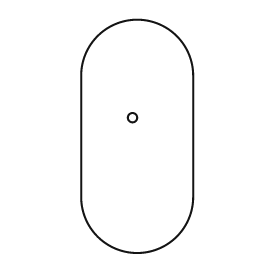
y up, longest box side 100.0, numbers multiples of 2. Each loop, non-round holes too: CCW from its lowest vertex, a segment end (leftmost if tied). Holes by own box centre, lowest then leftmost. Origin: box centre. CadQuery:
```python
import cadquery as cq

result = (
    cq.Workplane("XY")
    .moveTo(-24.0, -26.0)
    .threePointArc((0.0, -50.0), (24.0, -26.0))
    .lineTo(24.0, 26.0)
    .threePointArc((0.0, 50.0), (-24.0, 26.0))
    .close()
    .moveTo(-2.0, 8.0)
    .circle(2.0)
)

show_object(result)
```